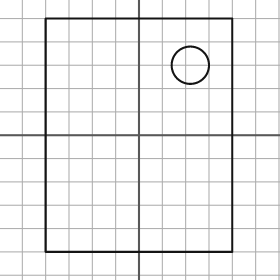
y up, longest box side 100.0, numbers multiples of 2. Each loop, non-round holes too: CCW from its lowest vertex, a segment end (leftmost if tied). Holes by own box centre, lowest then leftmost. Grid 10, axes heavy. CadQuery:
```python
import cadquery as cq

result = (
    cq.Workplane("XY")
    .moveTo(-40.0, -50.0)
    .lineTo(40.0, -50.0)
    .lineTo(40.0, 50.0)
    .lineTo(-40.0, 50.0)
    .close()
    .moveTo(22.0, 30.0)
    .circle(8.0)
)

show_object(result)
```